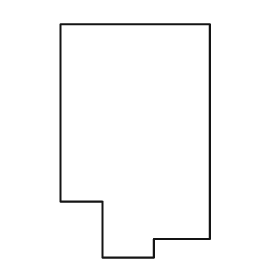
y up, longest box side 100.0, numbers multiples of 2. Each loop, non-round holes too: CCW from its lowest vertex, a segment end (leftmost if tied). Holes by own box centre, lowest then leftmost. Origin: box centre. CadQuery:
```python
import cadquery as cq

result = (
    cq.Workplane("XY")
    .moveTo(-14.0, -50.0)
    .lineTo(8.0, -50.0)
    .lineTo(8.0, -42.0)
    .lineTo(32.0, -42.0)
    .lineTo(32.0, 50.0)
    .lineTo(-32.0, 50.0)
    .lineTo(-32.0, -26.0)
    .lineTo(-14.0, -26.0)
    .close()
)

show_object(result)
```